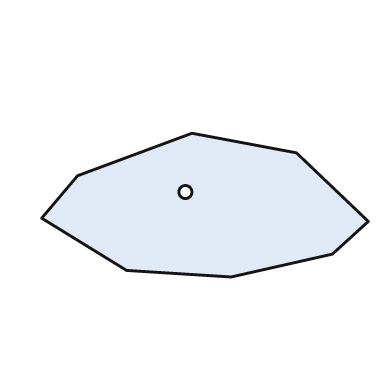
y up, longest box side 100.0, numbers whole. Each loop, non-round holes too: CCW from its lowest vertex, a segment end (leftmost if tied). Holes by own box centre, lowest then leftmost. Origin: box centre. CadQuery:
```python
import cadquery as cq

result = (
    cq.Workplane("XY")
    .moveTo(8.0, -22.0)
    .lineTo(39.0, -15.0)
    .lineTo(50.0, -5.0)
    .lineTo(28.0, 16.0)
    .lineTo(-4.0, 22.0)
    .lineTo(-39.0, 9.0)
    .lineTo(-50.0, -4.0)
    .lineTo(-24.0, -20.0)
    .close()
    .moveTo(-6.0, 4.0)
    .circle(2.0)
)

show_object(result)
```